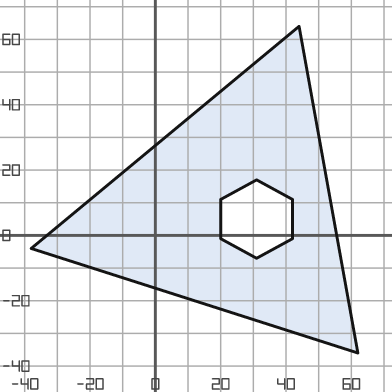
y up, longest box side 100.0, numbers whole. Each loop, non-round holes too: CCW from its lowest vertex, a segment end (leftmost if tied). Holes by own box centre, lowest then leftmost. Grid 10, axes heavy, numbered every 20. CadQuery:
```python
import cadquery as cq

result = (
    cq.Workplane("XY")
    .moveTo(62.0, -36.0)
    .lineTo(44.0, 64.0)
    .lineTo(-38.0, -4.0)
    .close()
    .moveTo(31.0, -7.0)
    .lineTo(42.0, -1.0)
    .lineTo(42.0, 11.0)
    .lineTo(31.0, 17.0)
    .lineTo(20.0, 11.0)
    .lineTo(20.0, -1.0)
    .close()
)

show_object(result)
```